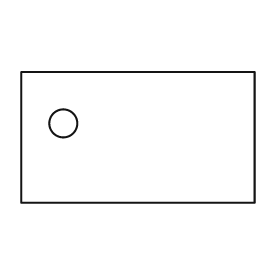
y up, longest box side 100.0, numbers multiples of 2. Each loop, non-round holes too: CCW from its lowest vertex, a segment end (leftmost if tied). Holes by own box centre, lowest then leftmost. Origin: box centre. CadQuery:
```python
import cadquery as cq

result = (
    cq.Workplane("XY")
    .moveTo(-50.0, -28.0)
    .lineTo(50.0, -28.0)
    .lineTo(50.0, 28.0)
    .lineTo(-50.0, 28.0)
    .close()
    .moveTo(-32.0, 6.0)
    .circle(6.0)
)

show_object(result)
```